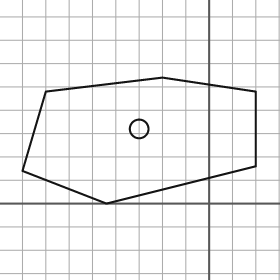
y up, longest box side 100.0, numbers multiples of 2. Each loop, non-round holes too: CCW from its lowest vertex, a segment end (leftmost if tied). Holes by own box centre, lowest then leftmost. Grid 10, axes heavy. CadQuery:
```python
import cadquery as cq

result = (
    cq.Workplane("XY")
    .moveTo(-44.0, 0.0)
    .lineTo(20.0, 16.0)
    .lineTo(20.0, 48.0)
    .lineTo(-20.0, 54.0)
    .lineTo(-70.0, 48.0)
    .lineTo(-80.0, 14.0)
    .close()
    .moveTo(-30.0, 32.0)
    .circle(4.0)
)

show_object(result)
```